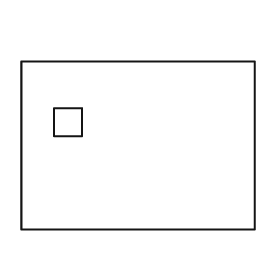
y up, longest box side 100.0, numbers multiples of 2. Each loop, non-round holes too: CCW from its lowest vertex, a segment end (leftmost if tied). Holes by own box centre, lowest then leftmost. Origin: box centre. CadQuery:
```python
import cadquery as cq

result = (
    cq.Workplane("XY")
    .moveTo(-50.0, -36.0)
    .lineTo(50.0, -36.0)
    .lineTo(50.0, 36.0)
    .lineTo(-50.0, 36.0)
    .close()
    .moveTo(-36.0, 4.0)
    .lineTo(-24.0, 4.0)
    .lineTo(-24.0, 16.0)
    .lineTo(-36.0, 16.0)
    .close()
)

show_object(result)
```